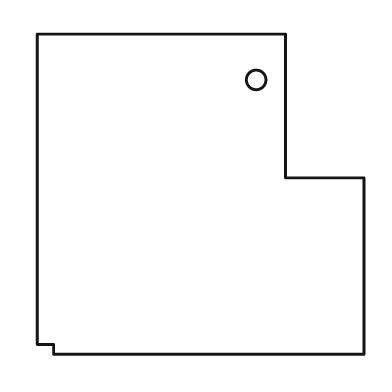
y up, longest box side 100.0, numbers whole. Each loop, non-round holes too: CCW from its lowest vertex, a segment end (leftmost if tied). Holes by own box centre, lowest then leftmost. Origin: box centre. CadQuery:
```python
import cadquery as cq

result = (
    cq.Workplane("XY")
    .moveTo(-45.0, -49.0)
    .lineTo(50.0, -49.0)
    .lineTo(50.0, 5.0)
    .lineTo(26.0, 5.0)
    .lineTo(26.0, 49.0)
    .lineTo(-50.0, 49.0)
    .lineTo(-50.0, -46.0)
    .lineTo(-45.0, -46.0)
    .close()
    .moveTo(17.0, 35.0)
    .circle(3.0)
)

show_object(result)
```